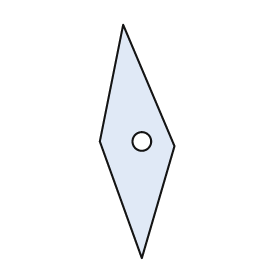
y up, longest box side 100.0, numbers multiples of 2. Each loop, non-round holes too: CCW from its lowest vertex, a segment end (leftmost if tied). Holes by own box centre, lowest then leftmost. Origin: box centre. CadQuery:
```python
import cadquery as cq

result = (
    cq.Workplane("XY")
    .moveTo(2.0, -50.0)
    .lineTo(16.0, -2.0)
    .lineTo(-6.0, 50.0)
    .lineTo(-16.0, 0.0)
    .close()
    .moveTo(2.0, 0.0)
    .circle(4.0)
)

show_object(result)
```